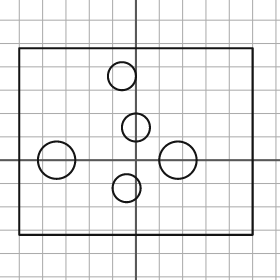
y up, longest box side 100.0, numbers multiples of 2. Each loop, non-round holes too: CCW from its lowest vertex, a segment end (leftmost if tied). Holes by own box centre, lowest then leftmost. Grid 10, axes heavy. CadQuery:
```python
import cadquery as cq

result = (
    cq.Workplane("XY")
    .moveTo(-50.0, -32.0)
    .lineTo(50.0, -32.0)
    .lineTo(50.0, 48.0)
    .lineTo(-50.0, 48.0)
    .close()
    .moveTo(-4.0, -12.0)
    .circle(6.0)
    .moveTo(-34.0, 0.0)
    .circle(8.0)
    .moveTo(18.0, 0.0)
    .circle(8.0)
    .moveTo(0.0, 14.0)
    .circle(6.0)
    .moveTo(-6.0, 36.0)
    .circle(6.0)
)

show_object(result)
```